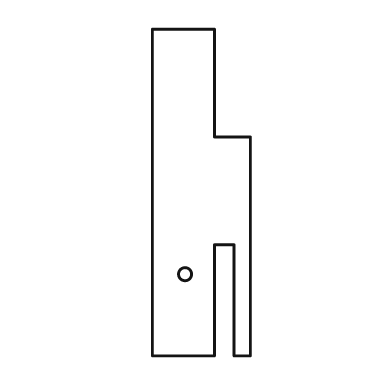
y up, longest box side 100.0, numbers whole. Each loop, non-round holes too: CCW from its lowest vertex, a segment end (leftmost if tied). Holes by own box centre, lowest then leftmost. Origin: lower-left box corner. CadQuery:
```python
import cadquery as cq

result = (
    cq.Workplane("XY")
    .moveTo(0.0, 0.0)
    .lineTo(19.0, 0.0)
    .lineTo(19.0, 34.0)
    .lineTo(25.0, 34.0)
    .lineTo(25.0, 0.0)
    .lineTo(30.0, 0.0)
    .lineTo(30.0, 67.0)
    .lineTo(19.0, 67.0)
    .lineTo(19.0, 100.0)
    .lineTo(0.0, 100.0)
    .close()
    .moveTo(10.0, 25.0)
    .circle(2.0)
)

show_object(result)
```